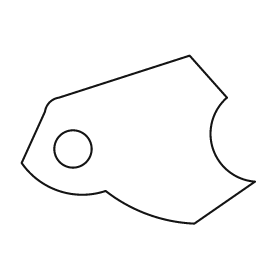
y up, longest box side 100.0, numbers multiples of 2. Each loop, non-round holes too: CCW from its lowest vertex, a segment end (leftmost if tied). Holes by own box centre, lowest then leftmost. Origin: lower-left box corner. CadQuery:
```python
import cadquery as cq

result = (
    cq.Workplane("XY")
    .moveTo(74.0, 0.0)
    .lineTo(100.0, 18.0)
    .threePointArc((82.0, 32.0), (88.0, 54.0))
    .lineTo(72.0, 72.0)
    .lineTo(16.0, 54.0)
    .threePointArc((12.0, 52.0), (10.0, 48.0))
    .lineTo(0.0, 26.0)
    .threePointArc((16.0, 14.0), (36.0, 14.0))
    .threePointArc((54.0, 4.0), (74.0, 0.0))
    .close()
    .moveTo(22.0, 32.0)
    .circle(8.0)
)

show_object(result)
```